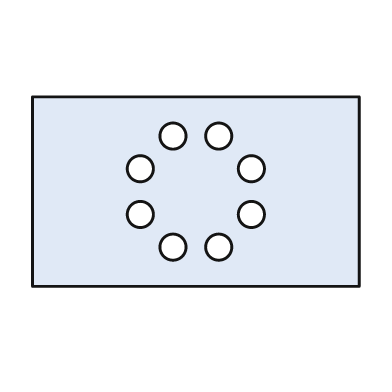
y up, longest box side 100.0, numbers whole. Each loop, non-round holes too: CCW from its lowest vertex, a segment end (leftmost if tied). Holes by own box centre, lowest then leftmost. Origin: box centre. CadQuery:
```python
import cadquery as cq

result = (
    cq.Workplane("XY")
    .moveTo(-50.0, -29.0)
    .lineTo(50.0, -29.0)
    .lineTo(50.0, 29.0)
    .lineTo(-50.0, 29.0)
    .close()
    .moveTo(-7.0, -17.0)
    .circle(4.0)
    .moveTo(7.0, -17.0)
    .circle(4.0)
    .moveTo(-17.0, -7.0)
    .circle(4.0)
    .moveTo(17.0, -7.0)
    .circle(4.0)
    .moveTo(-17.0, 7.0)
    .circle(4.0)
    .moveTo(17.0, 7.0)
    .circle(4.0)
    .moveTo(-7.0, 17.0)
    .circle(4.0)
    .moveTo(7.0, 17.0)
    .circle(4.0)
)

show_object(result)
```